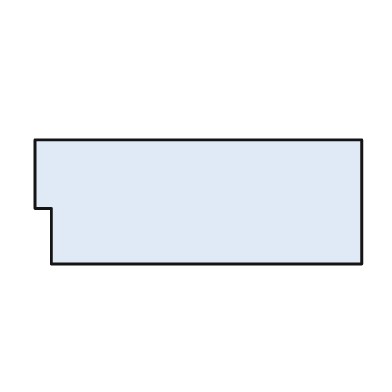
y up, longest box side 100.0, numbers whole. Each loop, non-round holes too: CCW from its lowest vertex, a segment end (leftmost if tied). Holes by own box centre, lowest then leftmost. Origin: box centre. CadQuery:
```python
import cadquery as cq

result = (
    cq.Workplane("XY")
    .moveTo(-45.0, -19.0)
    .lineTo(50.0, -19.0)
    .lineTo(50.0, 19.0)
    .lineTo(-50.0, 19.0)
    .lineTo(-50.0, -2.0)
    .lineTo(-45.0, -2.0)
    .close()
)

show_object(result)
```